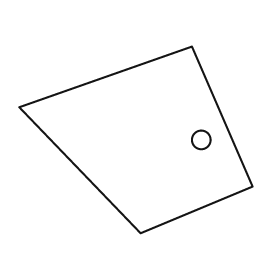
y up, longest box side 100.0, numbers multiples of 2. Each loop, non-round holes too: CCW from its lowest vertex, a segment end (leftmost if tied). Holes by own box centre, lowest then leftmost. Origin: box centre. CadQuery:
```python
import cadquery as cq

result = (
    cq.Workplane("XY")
    .moveTo(2.0, -40.0)
    .lineTo(50.0, -20.0)
    .lineTo(24.0, 40.0)
    .lineTo(-50.0, 14.0)
    .close()
    .moveTo(28.0, 0.0)
    .circle(4.0)
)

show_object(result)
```